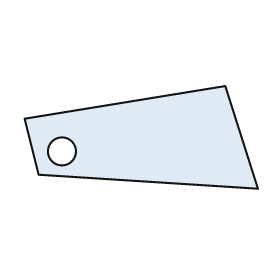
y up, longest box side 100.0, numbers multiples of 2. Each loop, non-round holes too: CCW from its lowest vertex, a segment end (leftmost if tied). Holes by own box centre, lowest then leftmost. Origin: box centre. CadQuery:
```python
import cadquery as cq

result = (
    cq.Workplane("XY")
    .moveTo(50.0, -22.0)
    .lineTo(36.0, 22.0)
    .lineTo(-50.0, 8.0)
    .lineTo(-44.0, -16.0)
    .close()
    .moveTo(-34.0, -6.0)
    .circle(6.0)
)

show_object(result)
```